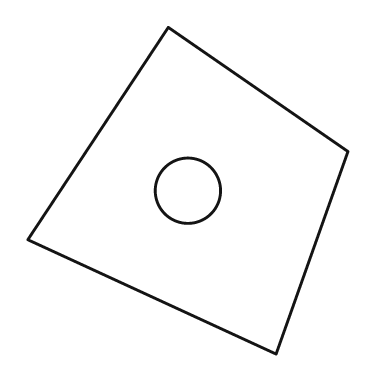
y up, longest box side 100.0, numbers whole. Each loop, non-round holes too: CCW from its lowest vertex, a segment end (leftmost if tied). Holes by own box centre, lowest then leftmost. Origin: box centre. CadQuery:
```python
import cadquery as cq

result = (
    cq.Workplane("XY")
    .moveTo(27.0, -50.0)
    .lineTo(49.0, 12.0)
    .lineTo(-6.0, 50.0)
    .lineTo(-49.0, -15.0)
    .close()
    .moveTo(0.0, 0.0)
    .circle(10.0)
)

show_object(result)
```